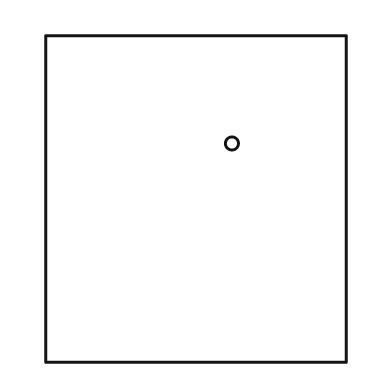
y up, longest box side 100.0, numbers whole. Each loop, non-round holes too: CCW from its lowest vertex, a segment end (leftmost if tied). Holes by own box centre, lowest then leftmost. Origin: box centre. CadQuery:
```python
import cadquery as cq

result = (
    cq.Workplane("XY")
    .moveTo(-46.0, -50.0)
    .lineTo(46.0, -50.0)
    .lineTo(46.0, 50.0)
    .lineTo(-46.0, 50.0)
    .close()
    .moveTo(11.0, 17.0)
    .circle(2.0)
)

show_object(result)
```